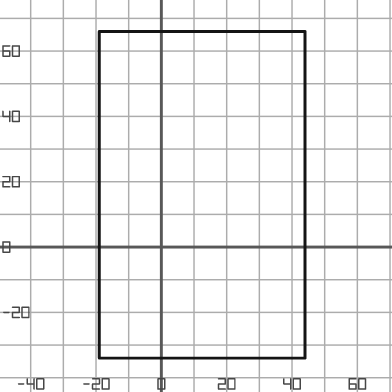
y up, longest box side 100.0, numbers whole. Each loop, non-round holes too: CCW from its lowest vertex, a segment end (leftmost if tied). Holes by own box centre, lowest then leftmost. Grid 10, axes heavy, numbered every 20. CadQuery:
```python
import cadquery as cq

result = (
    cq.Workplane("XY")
    .moveTo(-19.0, -34.0)
    .lineTo(44.0, -34.0)
    .lineTo(44.0, 66.0)
    .lineTo(-19.0, 66.0)
    .close()
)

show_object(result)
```